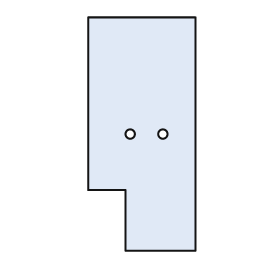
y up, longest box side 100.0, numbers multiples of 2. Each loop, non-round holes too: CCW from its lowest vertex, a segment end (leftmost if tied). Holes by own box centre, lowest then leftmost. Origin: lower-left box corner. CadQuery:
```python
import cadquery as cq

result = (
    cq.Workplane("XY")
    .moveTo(16.0, 0.0)
    .lineTo(46.0, 0.0)
    .lineTo(46.0, 100.0)
    .lineTo(0.0, 100.0)
    .lineTo(0.0, 26.0)
    .lineTo(16.0, 26.0)
    .close()
    .moveTo(18.0, 50.0)
    .circle(2.0)
    .moveTo(32.0, 50.0)
    .circle(2.0)
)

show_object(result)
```